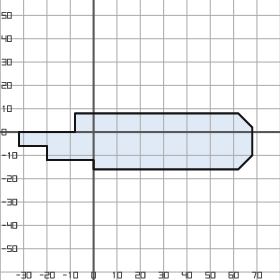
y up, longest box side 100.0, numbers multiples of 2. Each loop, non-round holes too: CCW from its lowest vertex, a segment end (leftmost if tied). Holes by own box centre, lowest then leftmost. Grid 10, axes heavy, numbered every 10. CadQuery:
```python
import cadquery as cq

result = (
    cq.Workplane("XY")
    .moveTo(0.0, -16.0)
    .lineTo(62.0, -16.0)
    .lineTo(68.0, -10.0)
    .lineTo(68.0, 2.0)
    .lineTo(62.0, 8.0)
    .lineTo(-8.0, 8.0)
    .lineTo(-8.0, 0.0)
    .lineTo(-32.0, 0.0)
    .lineTo(-32.0, -6.0)
    .lineTo(-20.0, -6.0)
    .lineTo(-20.0, -12.0)
    .lineTo(0.0, -12.0)
    .close()
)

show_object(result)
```